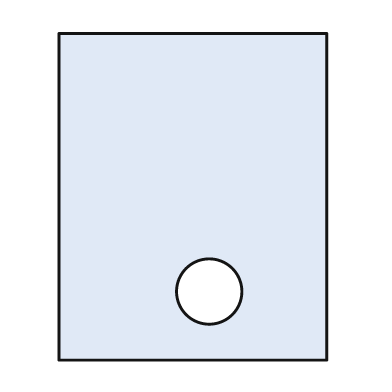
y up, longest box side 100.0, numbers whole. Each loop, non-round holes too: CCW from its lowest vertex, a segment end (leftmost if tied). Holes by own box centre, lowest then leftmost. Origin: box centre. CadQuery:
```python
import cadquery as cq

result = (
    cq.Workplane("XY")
    .moveTo(-41.0, -50.0)
    .lineTo(41.0, -50.0)
    .lineTo(41.0, 50.0)
    .lineTo(-41.0, 50.0)
    .close()
    .moveTo(5.0, -29.0)
    .circle(10.0)
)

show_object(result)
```